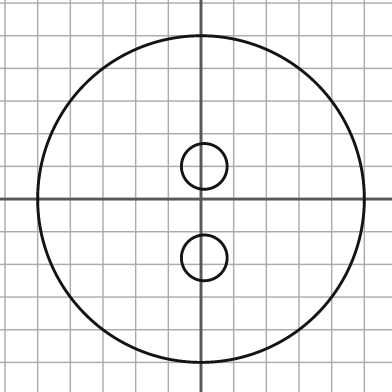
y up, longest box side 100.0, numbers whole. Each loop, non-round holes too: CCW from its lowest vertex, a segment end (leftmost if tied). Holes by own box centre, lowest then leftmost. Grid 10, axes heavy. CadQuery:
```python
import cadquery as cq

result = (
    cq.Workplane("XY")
    .moveTo(0.0, 0.0)
    .circle(50.0)
    .moveTo(1.0, -18.0)
    .circle(7.0)
    .moveTo(1.0, 10.0)
    .circle(7.0)
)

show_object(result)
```